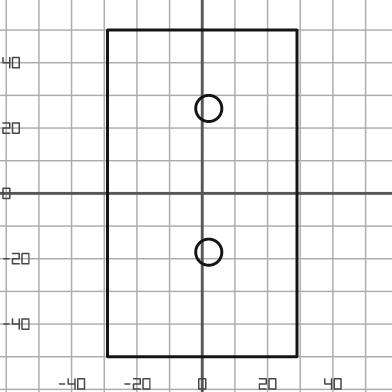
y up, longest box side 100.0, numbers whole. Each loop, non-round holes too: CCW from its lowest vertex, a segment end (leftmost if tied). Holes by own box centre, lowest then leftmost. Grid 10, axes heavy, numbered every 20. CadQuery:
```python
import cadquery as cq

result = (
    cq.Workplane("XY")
    .moveTo(-29.0, -50.0)
    .lineTo(29.0, -50.0)
    .lineTo(29.0, 50.0)
    .lineTo(-29.0, 50.0)
    .close()
    .moveTo(2.0, -18.0)
    .circle(4.0)
    .moveTo(2.0, 26.0)
    .circle(4.0)
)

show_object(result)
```